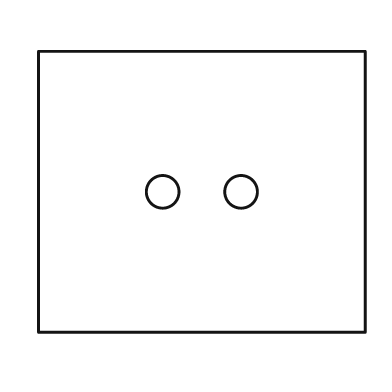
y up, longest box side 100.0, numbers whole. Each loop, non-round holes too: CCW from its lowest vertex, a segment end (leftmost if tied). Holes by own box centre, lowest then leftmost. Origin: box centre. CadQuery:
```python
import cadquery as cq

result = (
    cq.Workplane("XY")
    .moveTo(-50.0, -43.0)
    .lineTo(50.0, -43.0)
    .lineTo(50.0, 43.0)
    .lineTo(-50.0, 43.0)
    .close()
    .moveTo(-12.0, 0.0)
    .circle(5.0)
    .moveTo(12.0, 0.0)
    .circle(5.0)
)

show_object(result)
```